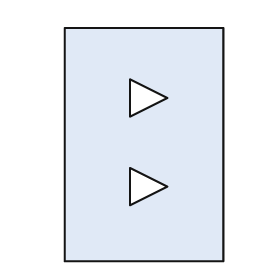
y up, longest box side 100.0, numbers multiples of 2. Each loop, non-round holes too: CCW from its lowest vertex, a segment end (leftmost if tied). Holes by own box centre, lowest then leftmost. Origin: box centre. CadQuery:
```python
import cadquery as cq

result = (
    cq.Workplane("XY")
    .moveTo(-34.0, -50.0)
    .lineTo(34.0, -50.0)
    .lineTo(34.0, 50.0)
    .lineTo(-34.0, 50.0)
    .close()
    .moveTo(-6.0, -26.0)
    .lineTo(10.0, -18.0)
    .lineTo(-6.0, -10.0)
    .close()
    .moveTo(-6.0, 12.0)
    .lineTo(10.0, 20.0)
    .lineTo(-6.0, 28.0)
    .close()
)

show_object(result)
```